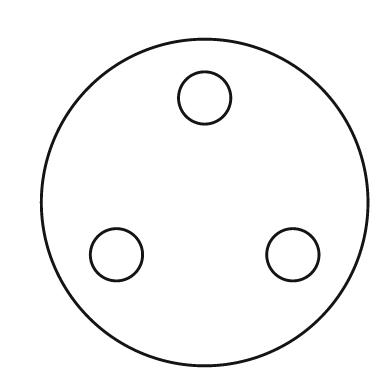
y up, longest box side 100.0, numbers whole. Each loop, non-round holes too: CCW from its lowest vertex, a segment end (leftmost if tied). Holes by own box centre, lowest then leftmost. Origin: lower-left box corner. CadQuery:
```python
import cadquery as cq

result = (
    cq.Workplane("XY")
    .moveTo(50.0, 50.0)
    .circle(50.0)
    .moveTo(23.0, 34.0)
    .circle(8.0)
    .moveTo(77.0, 34.0)
    .circle(8.0)
    .moveTo(50.0, 82.0)
    .circle(8.0)
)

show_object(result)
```